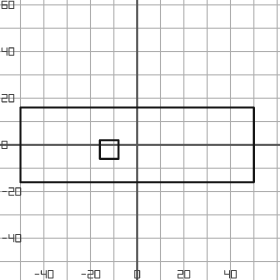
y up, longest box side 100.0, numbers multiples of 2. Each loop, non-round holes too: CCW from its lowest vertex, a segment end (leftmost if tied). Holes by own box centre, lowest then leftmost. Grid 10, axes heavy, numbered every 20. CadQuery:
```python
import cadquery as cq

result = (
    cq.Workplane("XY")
    .moveTo(-50.0, -16.0)
    .lineTo(50.0, -16.0)
    .lineTo(50.0, 16.0)
    .lineTo(-50.0, 16.0)
    .close()
    .moveTo(-16.0, -6.0)
    .lineTo(-8.0, -6.0)
    .lineTo(-8.0, 2.0)
    .lineTo(-16.0, 2.0)
    .close()
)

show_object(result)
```